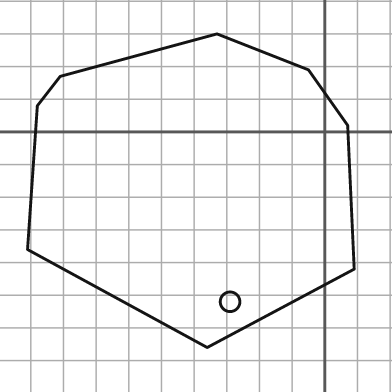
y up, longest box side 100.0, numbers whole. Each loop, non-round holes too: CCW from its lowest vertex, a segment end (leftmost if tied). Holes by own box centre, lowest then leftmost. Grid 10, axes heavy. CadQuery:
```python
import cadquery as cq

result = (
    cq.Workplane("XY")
    .moveTo(-36.0, -66.0)
    .lineTo(9.0, -42.0)
    .lineTo(7.0, 2.0)
    .lineTo(-5.0, 19.0)
    .lineTo(-33.0, 30.0)
    .lineTo(-81.0, 17.0)
    .lineTo(-88.0, 8.0)
    .lineTo(-91.0, -36.0)
    .close()
    .moveTo(-29.0, -52.0)
    .circle(3.0)
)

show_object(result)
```